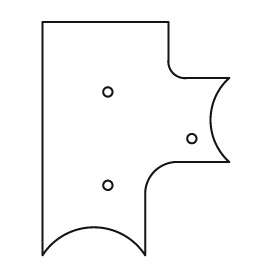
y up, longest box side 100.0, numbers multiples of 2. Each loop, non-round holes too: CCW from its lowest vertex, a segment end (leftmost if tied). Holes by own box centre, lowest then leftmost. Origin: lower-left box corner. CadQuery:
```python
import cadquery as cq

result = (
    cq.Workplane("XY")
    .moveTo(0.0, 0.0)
    .threePointArc((22.0, 12.0), (44.0, 0.0))
    .lineTo(44.0, 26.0)
    .threePointArc((48.0, 36.0), (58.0, 40.0))
    .lineTo(80.0, 40.0)
    .threePointArc((72.0, 58.0), (80.0, 76.0))
    .lineTo(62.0, 76.0)
    .threePointArc((56.0, 78.0), (54.0, 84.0))
    .lineTo(54.0, 100.0)
    .lineTo(0.0, 100.0)
    .close()
    .moveTo(28.0, 30.0)
    .circle(2.0)
    .moveTo(64.0, 50.0)
    .circle(2.0)
    .moveTo(28.0, 70.0)
    .circle(2.0)
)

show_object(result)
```